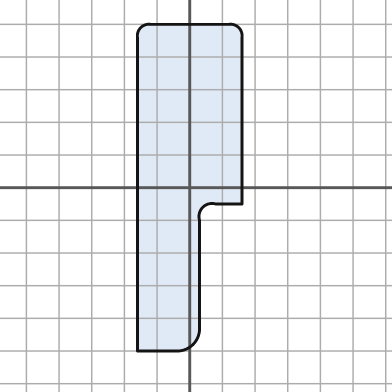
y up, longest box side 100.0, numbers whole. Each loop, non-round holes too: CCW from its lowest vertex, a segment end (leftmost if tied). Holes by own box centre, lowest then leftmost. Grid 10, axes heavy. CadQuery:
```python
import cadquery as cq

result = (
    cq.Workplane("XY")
    .moveTo(-16.0, -50.0)
    .lineTo(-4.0, -50.0)
    .threePointArc((1.0, -48.0), (3.0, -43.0))
    .lineTo(3.0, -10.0)
    .threePointArc((4.0, -6.0), (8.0, -5.0))
    .lineTo(16.0, -5.0)
    .lineTo(16.0, 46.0)
    .threePointArc((15.0, 49.0), (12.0, 50.0))
    .lineTo(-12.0, 50.0)
    .threePointArc((-15.0, 49.0), (-16.0, 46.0))
    .close()
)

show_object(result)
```